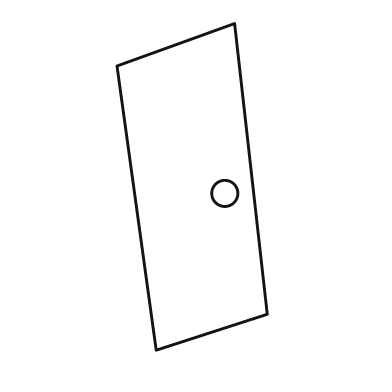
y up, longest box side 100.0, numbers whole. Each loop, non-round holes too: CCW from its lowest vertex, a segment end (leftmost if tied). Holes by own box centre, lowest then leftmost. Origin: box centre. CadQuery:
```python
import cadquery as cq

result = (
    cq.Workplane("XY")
    .moveTo(-11.0, -50.0)
    .lineTo(23.0, -39.0)
    .lineTo(13.0, 50.0)
    .lineTo(-23.0, 37.0)
    .close()
    .moveTo(10.0, -2.0)
    .circle(4.0)
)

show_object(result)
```